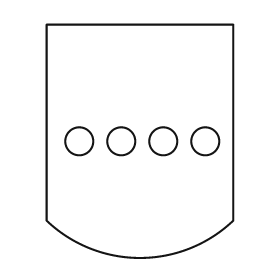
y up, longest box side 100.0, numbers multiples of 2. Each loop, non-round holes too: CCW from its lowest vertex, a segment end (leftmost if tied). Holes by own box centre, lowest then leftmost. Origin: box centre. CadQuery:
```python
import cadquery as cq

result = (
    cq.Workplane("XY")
    .moveTo(-40.0, -34.0)
    .threePointArc((0.0, -50.0), (40.0, -34.0))
    .lineTo(40.0, 50.0)
    .lineTo(-40.0, 50.0)
    .close()
    .moveTo(-26.0, 0.0)
    .circle(6.0)
    .moveTo(-8.0, 0.0)
    .circle(6.0)
    .moveTo(10.0, 0.0)
    .circle(6.0)
    .moveTo(28.0, 0.0)
    .circle(6.0)
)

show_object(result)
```